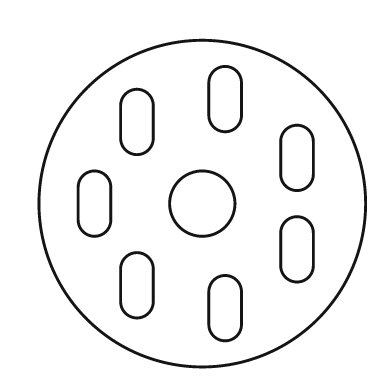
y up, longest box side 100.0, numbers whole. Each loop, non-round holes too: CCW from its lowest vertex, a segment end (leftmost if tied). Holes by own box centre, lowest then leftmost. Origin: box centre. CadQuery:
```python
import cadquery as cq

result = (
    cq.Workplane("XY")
    .moveTo(0.0, 0.0)
    .circle(50.0)
    .moveTo(2.0, -37.0)
    .threePointArc((7.0, -42.0), (12.0, -37.0))
    .lineTo(12.0, -27.0)
    .threePointArc((7.0, -22.0), (2.0, -27.0))
    .close()
    .moveTo(-25.0, -30.0)
    .threePointArc((-20.0, -35.0), (-15.0, -30.0))
    .lineTo(-15.0, -20.0)
    .threePointArc((-20.0, -15.0), (-25.0, -20.0))
    .close()
    .moveTo(24.0, -19.0)
    .threePointArc((29.0, -24.0), (34.0, -19.0))
    .lineTo(34.0, -9.0)
    .threePointArc((29.0, -4.0), (24.0, -9.0))
    .close()
    .moveTo(-38.0, -5.0)
    .threePointArc((-33.0, -10.0), (-28.0, -5.0))
    .lineTo(-28.0, 5.0)
    .threePointArc((-33.0, 10.0), (-38.0, 5.0))
    .close()
    .moveTo(0.0, 0.0)
    .circle(10.0)
    .moveTo(24.0, 9.0)
    .threePointArc((29.0, 4.0), (34.0, 9.0))
    .lineTo(34.0, 19.0)
    .threePointArc((29.0, 24.0), (24.0, 19.0))
    .close()
    .moveTo(-25.0, 20.0)
    .threePointArc((-20.0, 15.0), (-15.0, 20.0))
    .lineTo(-15.0, 30.0)
    .threePointArc((-20.0, 35.0), (-25.0, 30.0))
    .close()
    .moveTo(2.0, 27.0)
    .threePointArc((7.0, 22.0), (12.0, 27.0))
    .lineTo(12.0, 37.0)
    .threePointArc((7.0, 42.0), (2.0, 37.0))
    .close()
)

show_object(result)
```